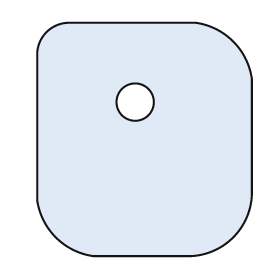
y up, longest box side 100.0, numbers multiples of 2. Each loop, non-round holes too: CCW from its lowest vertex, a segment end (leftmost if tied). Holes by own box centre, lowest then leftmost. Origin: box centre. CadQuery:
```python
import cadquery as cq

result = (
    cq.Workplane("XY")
    .moveTo(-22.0, -50.0)
    .lineTo(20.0, -50.0)
    .threePointArc((38.0, -42.0), (46.0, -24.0))
    .lineTo(46.0, 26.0)
    .threePointArc((38.0, 42.0), (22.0, 50.0))
    .lineTo(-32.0, 50.0)
    .threePointArc((-42.0, 46.0), (-46.0, 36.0))
    .lineTo(-46.0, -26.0)
    .threePointArc((-38.0, -42.0), (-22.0, -50.0))
    .close()
    .moveTo(-4.0, 16.0)
    .circle(8.0)
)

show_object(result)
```